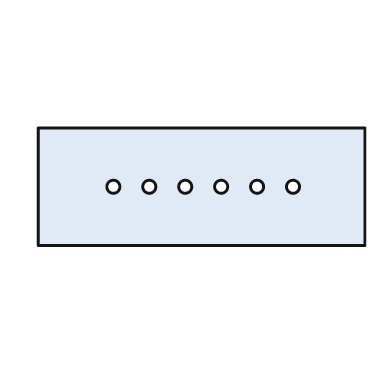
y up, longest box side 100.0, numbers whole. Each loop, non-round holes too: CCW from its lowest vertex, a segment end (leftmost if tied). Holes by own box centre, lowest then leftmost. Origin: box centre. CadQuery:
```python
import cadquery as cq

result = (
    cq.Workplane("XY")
    .moveTo(-50.0, -18.0)
    .lineTo(50.0, -18.0)
    .lineTo(50.0, 18.0)
    .lineTo(-50.0, 18.0)
    .close()
    .moveTo(-27.0, 0.0)
    .circle(2.0)
    .moveTo(-16.0, 0.0)
    .circle(2.0)
    .moveTo(-5.0, 0.0)
    .circle(2.0)
    .moveTo(6.0, 0.0)
    .circle(2.0)
    .moveTo(17.0, 0.0)
    .circle(2.0)
    .moveTo(28.0, 0.0)
    .circle(2.0)
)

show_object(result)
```